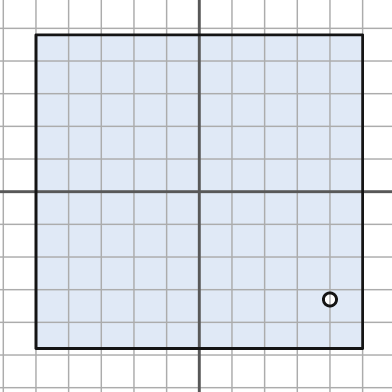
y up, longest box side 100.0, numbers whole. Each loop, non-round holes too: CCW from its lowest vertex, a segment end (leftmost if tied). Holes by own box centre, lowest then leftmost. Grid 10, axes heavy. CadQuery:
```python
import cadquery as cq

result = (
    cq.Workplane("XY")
    .moveTo(-50.0, -48.0)
    .lineTo(50.0, -48.0)
    .lineTo(50.0, 48.0)
    .lineTo(-50.0, 48.0)
    .close()
    .moveTo(40.0, -33.0)
    .circle(2.0)
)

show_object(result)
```